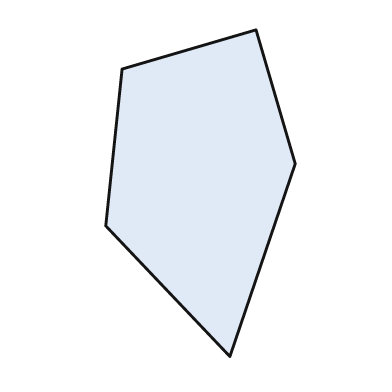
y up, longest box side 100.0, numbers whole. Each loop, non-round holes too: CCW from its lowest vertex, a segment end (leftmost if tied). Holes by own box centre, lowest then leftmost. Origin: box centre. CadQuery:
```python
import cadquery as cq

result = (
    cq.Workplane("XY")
    .moveTo(9.0, -50.0)
    .lineTo(29.0, 9.0)
    .lineTo(17.0, 50.0)
    .lineTo(-24.0, 38.0)
    .lineTo(-29.0, -10.0)
    .close()
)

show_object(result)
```